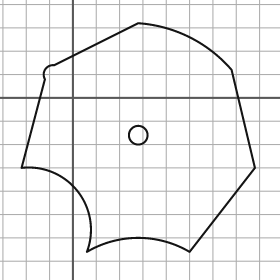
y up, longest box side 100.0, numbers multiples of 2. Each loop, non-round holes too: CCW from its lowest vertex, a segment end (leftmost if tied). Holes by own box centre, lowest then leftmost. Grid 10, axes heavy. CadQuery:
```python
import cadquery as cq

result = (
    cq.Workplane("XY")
    .moveTo(6.0, -66.0)
    .threePointArc((28.0, -60.0), (50.0, -66.0))
    .lineTo(78.0, -30.0)
    .lineTo(68.0, 12.0)
    .threePointArc((50.0, 26.0), (28.0, 32.0))
    .lineTo(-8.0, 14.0)
    .threePointArc((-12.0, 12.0), (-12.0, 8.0))
    .lineTo(-22.0, -30.0)
    .threePointArc((2.0, -40.0), (6.0, -66.0))
    .close()
    .moveTo(28.0, -16.0)
    .circle(4.0)
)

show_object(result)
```